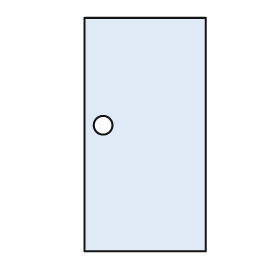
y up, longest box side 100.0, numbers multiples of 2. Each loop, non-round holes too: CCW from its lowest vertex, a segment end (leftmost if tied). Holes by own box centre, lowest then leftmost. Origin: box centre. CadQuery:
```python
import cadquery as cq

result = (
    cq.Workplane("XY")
    .moveTo(-26.0, -50.0)
    .lineTo(26.0, -50.0)
    .lineTo(26.0, 50.0)
    .lineTo(-26.0, 50.0)
    .close()
    .moveTo(-18.0, 4.0)
    .circle(4.0)
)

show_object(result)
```